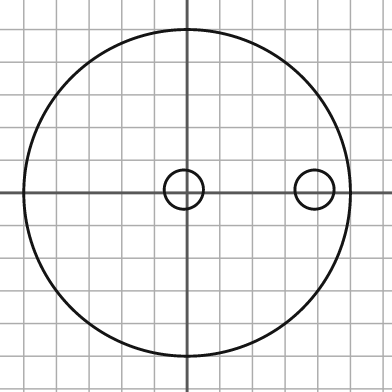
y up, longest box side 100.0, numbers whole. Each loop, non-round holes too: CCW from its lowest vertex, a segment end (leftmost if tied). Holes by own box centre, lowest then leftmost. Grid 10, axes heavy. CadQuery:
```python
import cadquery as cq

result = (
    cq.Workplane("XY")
    .moveTo(0.0, 0.0)
    .circle(50.0)
    .moveTo(-1.0, 1.0)
    .circle(6.0)
    .moveTo(39.0, 1.0)
    .circle(6.0)
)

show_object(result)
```